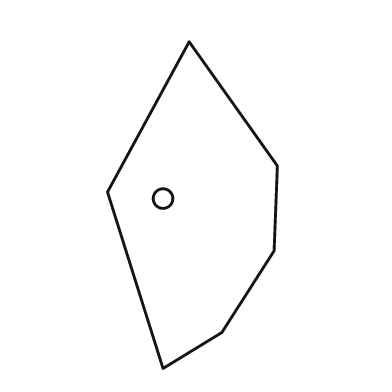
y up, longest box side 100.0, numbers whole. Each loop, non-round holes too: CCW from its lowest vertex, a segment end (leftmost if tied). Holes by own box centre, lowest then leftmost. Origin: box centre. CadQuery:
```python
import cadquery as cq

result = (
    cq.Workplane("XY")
    .moveTo(-9.0, -50.0)
    .lineTo(9.0, -39.0)
    .lineTo(25.0, -14.0)
    .lineTo(26.0, 12.0)
    .lineTo(-1.0, 50.0)
    .lineTo(-26.0, 4.0)
    .close()
    .moveTo(-9.0, 2.0)
    .circle(3.0)
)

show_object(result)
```